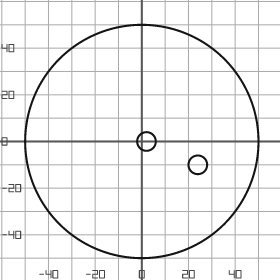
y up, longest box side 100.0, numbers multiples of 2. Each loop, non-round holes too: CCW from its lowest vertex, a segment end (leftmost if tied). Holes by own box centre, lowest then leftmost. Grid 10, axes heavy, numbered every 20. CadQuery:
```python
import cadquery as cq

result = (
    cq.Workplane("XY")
    .moveTo(0.0, 0.0)
    .circle(50.0)
    .moveTo(24.0, -10.0)
    .circle(4.0)
    .moveTo(2.0, 0.0)
    .circle(4.0)
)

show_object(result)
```